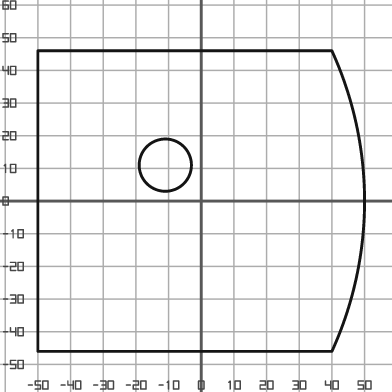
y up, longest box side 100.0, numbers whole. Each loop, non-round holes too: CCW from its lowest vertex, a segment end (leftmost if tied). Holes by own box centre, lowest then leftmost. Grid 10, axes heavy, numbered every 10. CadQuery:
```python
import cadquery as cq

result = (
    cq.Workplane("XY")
    .moveTo(-50.0, -46.0)
    .lineTo(40.0, -46.0)
    .threePointArc((50.0, 0.0), (40.0, 46.0))
    .lineTo(-50.0, 46.0)
    .close()
    .moveTo(-11.0, 11.0)
    .circle(8.0)
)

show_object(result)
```